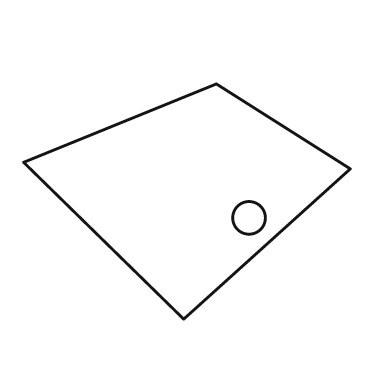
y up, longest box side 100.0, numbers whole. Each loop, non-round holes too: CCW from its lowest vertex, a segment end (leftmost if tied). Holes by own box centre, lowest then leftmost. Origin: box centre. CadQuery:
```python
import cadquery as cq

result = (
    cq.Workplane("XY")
    .moveTo(-1.0, -36.0)
    .lineTo(50.0, 10.0)
    .lineTo(9.0, 36.0)
    .lineTo(-50.0, 12.0)
    .close()
    .moveTo(19.0, -5.0)
    .circle(5.0)
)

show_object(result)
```